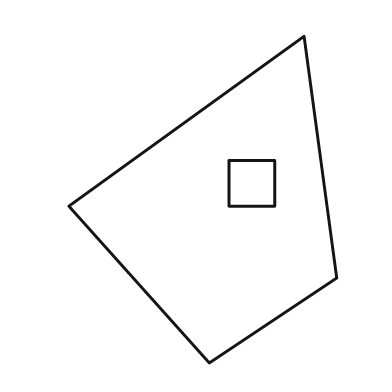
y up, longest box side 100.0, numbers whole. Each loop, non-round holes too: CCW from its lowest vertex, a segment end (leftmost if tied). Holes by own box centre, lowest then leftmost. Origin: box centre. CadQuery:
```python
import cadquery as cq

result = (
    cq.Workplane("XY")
    .moveTo(2.0, -50.0)
    .lineTo(41.0, -24.0)
    .lineTo(31.0, 50.0)
    .lineTo(-41.0, -2.0)
    .close()
    .moveTo(8.0, -2.0)
    .lineTo(22.0, -2.0)
    .lineTo(22.0, 12.0)
    .lineTo(8.0, 12.0)
    .close()
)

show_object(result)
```